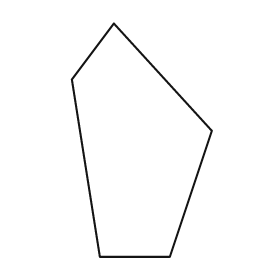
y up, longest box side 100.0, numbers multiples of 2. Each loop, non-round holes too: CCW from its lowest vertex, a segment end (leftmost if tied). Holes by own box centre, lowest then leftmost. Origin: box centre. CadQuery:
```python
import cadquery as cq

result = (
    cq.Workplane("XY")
    .moveTo(-18.0, -50.0)
    .lineTo(12.0, -50.0)
    .lineTo(30.0, 4.0)
    .lineTo(-12.0, 50.0)
    .lineTo(-30.0, 26.0)
    .close()
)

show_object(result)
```